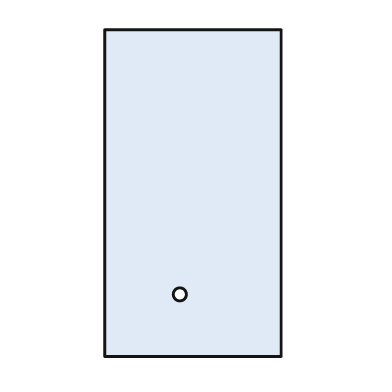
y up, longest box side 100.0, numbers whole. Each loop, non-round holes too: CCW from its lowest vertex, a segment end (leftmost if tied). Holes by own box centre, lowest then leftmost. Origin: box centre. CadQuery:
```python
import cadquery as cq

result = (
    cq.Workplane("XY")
    .moveTo(-27.0, -50.0)
    .lineTo(27.0, -50.0)
    .lineTo(27.0, 50.0)
    .lineTo(-27.0, 50.0)
    .close()
    .moveTo(-4.0, -31.0)
    .circle(2.0)
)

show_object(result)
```